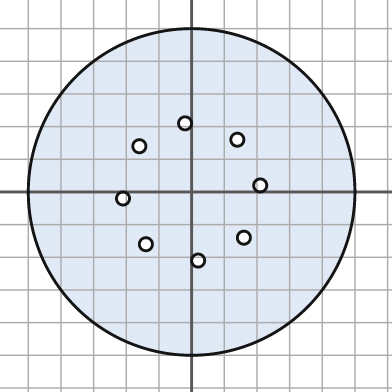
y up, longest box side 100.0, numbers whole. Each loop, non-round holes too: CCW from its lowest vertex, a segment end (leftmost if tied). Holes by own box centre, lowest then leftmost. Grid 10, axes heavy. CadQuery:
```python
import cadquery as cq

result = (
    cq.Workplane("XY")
    .moveTo(0.0, 0.0)
    .circle(50.0)
    .moveTo(2.0, -21.0)
    .circle(2.0)
    .moveTo(-14.0, -16.0)
    .circle(2.0)
    .moveTo(16.0, -14.0)
    .circle(2.0)
    .moveTo(-21.0, -2.0)
    .circle(2.0)
    .moveTo(21.0, 2.0)
    .circle(2.0)
    .moveTo(-16.0, 14.0)
    .circle(2.0)
    .moveTo(14.0, 16.0)
    .circle(2.0)
    .moveTo(-2.0, 21.0)
    .circle(2.0)
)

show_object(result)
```